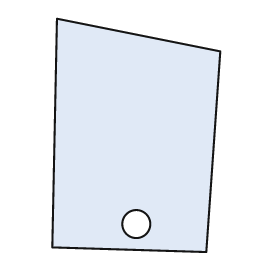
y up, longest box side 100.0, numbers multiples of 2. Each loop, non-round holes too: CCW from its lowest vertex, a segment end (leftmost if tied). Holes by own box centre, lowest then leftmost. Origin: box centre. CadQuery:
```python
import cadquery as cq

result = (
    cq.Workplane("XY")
    .moveTo(30.0, -50.0)
    .lineTo(36.0, 36.0)
    .lineTo(-34.0, 50.0)
    .lineTo(-36.0, -48.0)
    .close()
    .moveTo(0.0, -38.0)
    .circle(6.0)
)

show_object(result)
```